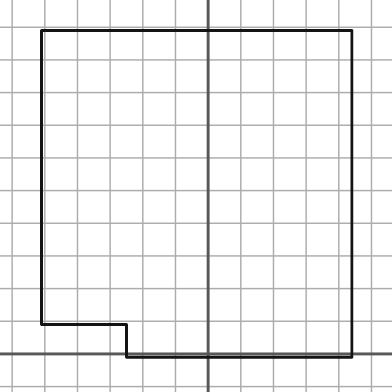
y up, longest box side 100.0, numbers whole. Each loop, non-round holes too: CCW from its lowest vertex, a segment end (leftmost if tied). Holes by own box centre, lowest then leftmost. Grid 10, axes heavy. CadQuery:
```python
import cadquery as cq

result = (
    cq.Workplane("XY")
    .moveTo(-25.0, -1.0)
    .lineTo(44.0, -1.0)
    .lineTo(44.0, 99.0)
    .lineTo(-51.0, 99.0)
    .lineTo(-51.0, 9.0)
    .lineTo(-25.0, 9.0)
    .close()
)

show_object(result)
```